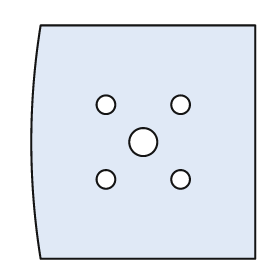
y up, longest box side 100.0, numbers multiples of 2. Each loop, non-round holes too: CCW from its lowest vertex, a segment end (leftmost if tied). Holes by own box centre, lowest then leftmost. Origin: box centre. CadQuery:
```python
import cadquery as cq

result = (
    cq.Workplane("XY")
    .moveTo(-44.0, -50.0)
    .lineTo(48.0, -50.0)
    .lineTo(48.0, 50.0)
    .lineTo(-44.0, 50.0)
    .threePointArc((-48.0, 0.0), (-44.0, -50.0))
    .close()
    .moveTo(-16.0, -16.0)
    .circle(4.0)
    .moveTo(16.0, -16.0)
    .circle(4.0)
    .moveTo(0.0, 0.0)
    .circle(6.0)
    .moveTo(-16.0, 16.0)
    .circle(4.0)
    .moveTo(16.0, 16.0)
    .circle(4.0)
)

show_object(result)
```